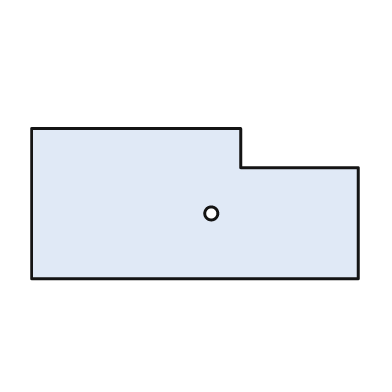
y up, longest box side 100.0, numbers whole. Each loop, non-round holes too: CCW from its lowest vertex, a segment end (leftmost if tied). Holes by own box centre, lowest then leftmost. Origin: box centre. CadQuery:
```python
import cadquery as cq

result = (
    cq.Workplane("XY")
    .moveTo(-50.0, -23.0)
    .lineTo(50.0, -23.0)
    .lineTo(50.0, 11.0)
    .lineTo(14.0, 11.0)
    .lineTo(14.0, 23.0)
    .lineTo(-50.0, 23.0)
    .close()
    .moveTo(5.0, -3.0)
    .circle(2.0)
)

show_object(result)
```